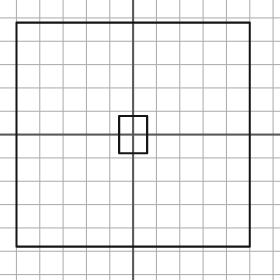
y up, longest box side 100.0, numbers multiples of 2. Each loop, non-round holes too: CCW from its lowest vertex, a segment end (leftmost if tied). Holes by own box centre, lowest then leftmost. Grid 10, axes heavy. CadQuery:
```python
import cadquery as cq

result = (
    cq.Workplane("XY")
    .moveTo(-50.0, -48.0)
    .lineTo(50.0, -48.0)
    .lineTo(50.0, 48.0)
    .lineTo(-50.0, 48.0)
    .close()
    .moveTo(-6.0, -8.0)
    .lineTo(6.0, -8.0)
    .lineTo(6.0, 8.0)
    .lineTo(-6.0, 8.0)
    .close()
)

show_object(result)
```